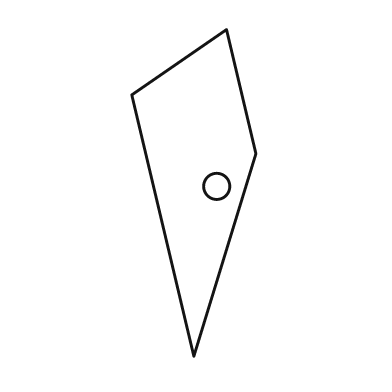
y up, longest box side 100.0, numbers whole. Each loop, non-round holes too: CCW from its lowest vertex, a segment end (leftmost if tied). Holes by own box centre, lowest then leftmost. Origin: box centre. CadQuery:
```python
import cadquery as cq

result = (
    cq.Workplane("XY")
    .moveTo(0.0, -50.0)
    .lineTo(19.0, 12.0)
    .lineTo(10.0, 50.0)
    .lineTo(-19.0, 30.0)
    .close()
    .moveTo(7.0, 2.0)
    .circle(4.0)
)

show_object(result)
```